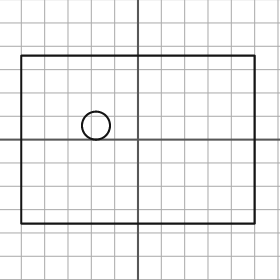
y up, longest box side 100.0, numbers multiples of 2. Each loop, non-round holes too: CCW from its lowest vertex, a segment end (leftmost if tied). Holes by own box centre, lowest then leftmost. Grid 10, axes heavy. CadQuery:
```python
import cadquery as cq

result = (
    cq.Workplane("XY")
    .moveTo(-50.0, -36.0)
    .lineTo(50.0, -36.0)
    .lineTo(50.0, 36.0)
    .lineTo(-50.0, 36.0)
    .close()
    .moveTo(-18.0, 6.0)
    .circle(6.0)
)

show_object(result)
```